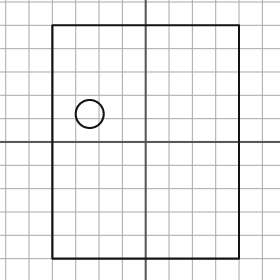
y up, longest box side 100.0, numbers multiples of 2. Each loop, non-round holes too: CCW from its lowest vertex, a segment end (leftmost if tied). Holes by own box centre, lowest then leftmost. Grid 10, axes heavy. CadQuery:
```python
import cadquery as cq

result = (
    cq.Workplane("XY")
    .moveTo(-40.0, -50.0)
    .lineTo(40.0, -50.0)
    .lineTo(40.0, 50.0)
    .lineTo(-40.0, 50.0)
    .close()
    .moveTo(-24.0, 12.0)
    .circle(6.0)
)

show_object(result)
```